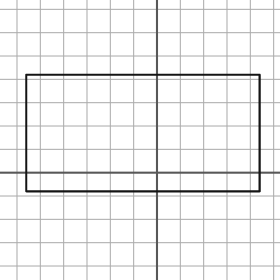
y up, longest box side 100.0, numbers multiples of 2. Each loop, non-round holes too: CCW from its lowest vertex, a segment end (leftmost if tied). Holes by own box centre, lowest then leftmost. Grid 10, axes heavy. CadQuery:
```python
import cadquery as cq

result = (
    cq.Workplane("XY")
    .moveTo(-56.0, -8.0)
    .lineTo(44.0, -8.0)
    .lineTo(44.0, 42.0)
    .lineTo(-56.0, 42.0)
    .close()
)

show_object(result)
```